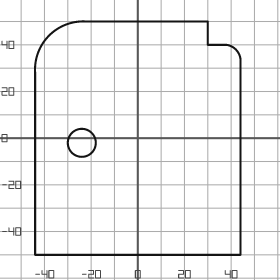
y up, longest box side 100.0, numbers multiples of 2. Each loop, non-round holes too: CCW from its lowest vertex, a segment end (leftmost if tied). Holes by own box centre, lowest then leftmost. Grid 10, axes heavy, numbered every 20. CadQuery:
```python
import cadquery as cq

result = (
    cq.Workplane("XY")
    .moveTo(-44.0, -50.0)
    .lineTo(44.0, -50.0)
    .lineTo(44.0, 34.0)
    .threePointArc((42.0, 38.0), (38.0, 40.0))
    .lineTo(30.0, 40.0)
    .lineTo(30.0, 50.0)
    .lineTo(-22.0, 50.0)
    .threePointArc((-38.0, 44.0), (-44.0, 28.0))
    .close()
    .moveTo(-24.0, -2.0)
    .circle(6.0)
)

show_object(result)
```